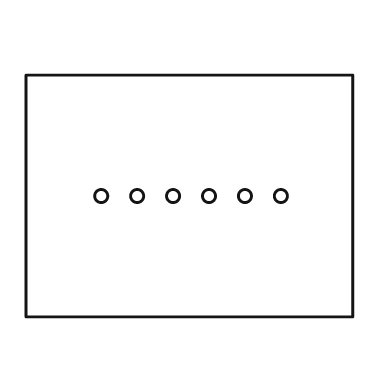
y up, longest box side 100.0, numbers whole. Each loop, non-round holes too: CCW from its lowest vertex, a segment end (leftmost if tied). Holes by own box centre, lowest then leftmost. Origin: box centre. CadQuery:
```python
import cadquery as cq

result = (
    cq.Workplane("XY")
    .moveTo(-50.0, -37.0)
    .lineTo(50.0, -37.0)
    .lineTo(50.0, 37.0)
    .lineTo(-50.0, 37.0)
    .close()
    .moveTo(-27.0, 0.0)
    .circle(2.0)
    .moveTo(-16.0, 0.0)
    .circle(2.0)
    .moveTo(-5.0, 0.0)
    .circle(2.0)
    .moveTo(6.0, 0.0)
    .circle(2.0)
    .moveTo(17.0, 0.0)
    .circle(2.0)
    .moveTo(28.0, 0.0)
    .circle(2.0)
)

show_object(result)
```